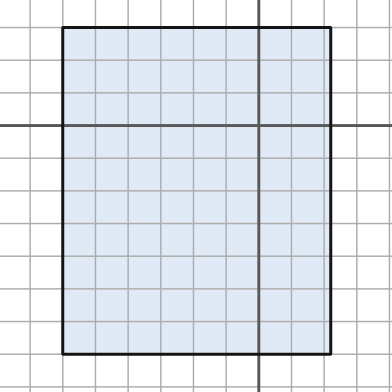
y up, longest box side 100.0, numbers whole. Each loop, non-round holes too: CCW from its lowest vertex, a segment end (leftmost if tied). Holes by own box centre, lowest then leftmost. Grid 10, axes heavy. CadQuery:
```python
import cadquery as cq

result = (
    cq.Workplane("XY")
    .moveTo(-60.0, -70.0)
    .lineTo(22.0, -70.0)
    .lineTo(22.0, 30.0)
    .lineTo(-60.0, 30.0)
    .close()
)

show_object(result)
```